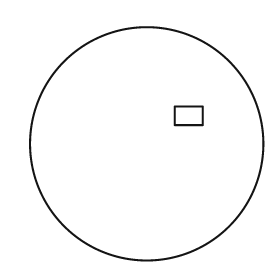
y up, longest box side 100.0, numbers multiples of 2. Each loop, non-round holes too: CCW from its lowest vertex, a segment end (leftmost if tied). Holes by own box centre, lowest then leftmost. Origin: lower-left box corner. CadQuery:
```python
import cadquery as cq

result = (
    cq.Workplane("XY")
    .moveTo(50.0, 50.0)
    .circle(50.0)
    .moveTo(62.0, 58.0)
    .lineTo(74.0, 58.0)
    .lineTo(74.0, 66.0)
    .lineTo(62.0, 66.0)
    .close()
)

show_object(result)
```